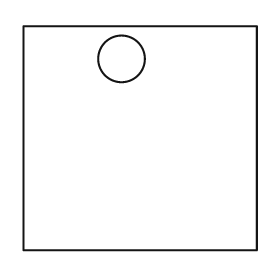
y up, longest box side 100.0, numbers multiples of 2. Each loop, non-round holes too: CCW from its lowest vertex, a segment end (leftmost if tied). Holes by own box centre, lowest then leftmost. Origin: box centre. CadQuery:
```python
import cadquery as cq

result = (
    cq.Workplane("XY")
    .moveTo(-50.0, -48.0)
    .lineTo(50.0, -48.0)
    .lineTo(50.0, 48.0)
    .lineTo(-50.0, 48.0)
    .close()
    .moveTo(-8.0, 34.0)
    .circle(10.0)
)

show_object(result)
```